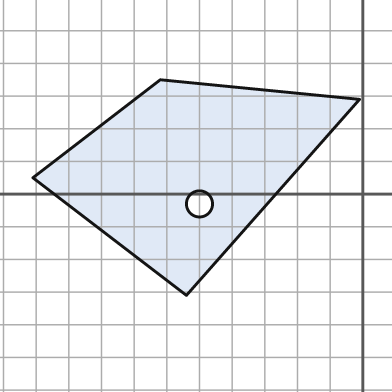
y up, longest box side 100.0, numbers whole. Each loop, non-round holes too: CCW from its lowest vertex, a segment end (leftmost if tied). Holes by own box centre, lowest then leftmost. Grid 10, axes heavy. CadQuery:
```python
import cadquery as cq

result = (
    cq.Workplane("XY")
    .moveTo(-54.0, -31.0)
    .lineTo(-1.0, 29.0)
    .lineTo(-62.0, 35.0)
    .lineTo(-101.0, 5.0)
    .close()
    .moveTo(-50.0, -3.0)
    .circle(4.0)
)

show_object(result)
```